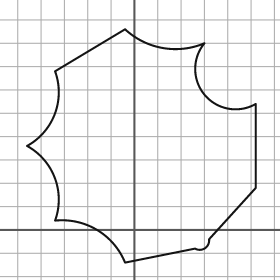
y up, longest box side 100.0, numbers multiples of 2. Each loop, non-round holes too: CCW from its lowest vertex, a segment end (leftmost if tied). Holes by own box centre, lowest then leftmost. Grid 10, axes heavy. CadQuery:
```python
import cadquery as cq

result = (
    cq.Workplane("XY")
    .moveTo(-4.0, -14.0)
    .lineTo(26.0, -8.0)
    .threePointArc((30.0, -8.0), (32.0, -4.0))
    .lineTo(52.0, 18.0)
    .lineTo(52.0, 54.0)
    .threePointArc((30.0, 58.0), (30.0, 80.0))
    .threePointArc((12.0, 78.0), (-4.0, 86.0))
    .lineTo(-34.0, 68.0)
    .threePointArc((-34.0, 50.0), (-46.0, 36.0))
    .threePointArc((-34.0, 22.0), (-34.0, 4.0))
    .threePointArc((-16.0, 0.0), (-4.0, -14.0))
    .close()
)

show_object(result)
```